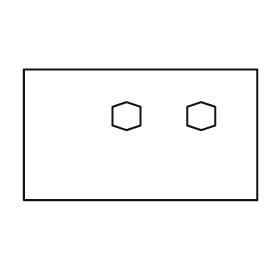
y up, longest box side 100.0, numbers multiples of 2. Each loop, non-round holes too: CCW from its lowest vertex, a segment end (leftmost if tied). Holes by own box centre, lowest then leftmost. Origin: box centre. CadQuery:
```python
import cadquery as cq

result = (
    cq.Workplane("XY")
    .moveTo(-50.0, -28.0)
    .lineTo(50.0, -28.0)
    .lineTo(50.0, 28.0)
    .lineTo(-50.0, 28.0)
    .close()
    .moveTo(-6.0, 2.0)
    .lineTo(0.0, 4.0)
    .lineTo(0.0, 12.0)
    .lineTo(-6.0, 14.0)
    .lineTo(-12.0, 12.0)
    .lineTo(-12.0, 4.0)
    .close()
    .moveTo(26.0, 2.0)
    .lineTo(32.0, 4.0)
    .lineTo(32.0, 12.0)
    .lineTo(26.0, 14.0)
    .lineTo(20.0, 12.0)
    .lineTo(20.0, 4.0)
    .close()
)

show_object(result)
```